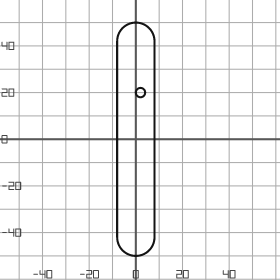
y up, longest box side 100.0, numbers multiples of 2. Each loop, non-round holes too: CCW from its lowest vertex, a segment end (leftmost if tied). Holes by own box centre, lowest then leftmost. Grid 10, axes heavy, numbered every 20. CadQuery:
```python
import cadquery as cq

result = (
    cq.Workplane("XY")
    .moveTo(-8.0, -42.0)
    .threePointArc((0.0, -50.0), (8.0, -42.0))
    .lineTo(8.0, 42.0)
    .threePointArc((0.0, 50.0), (-8.0, 42.0))
    .close()
    .moveTo(2.0, 20.0)
    .circle(2.0)
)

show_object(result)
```